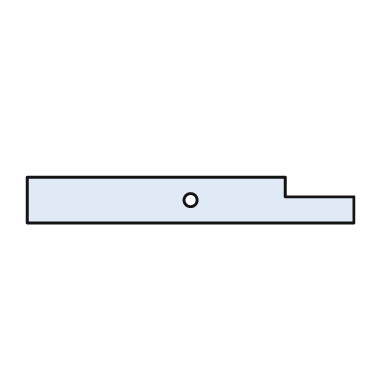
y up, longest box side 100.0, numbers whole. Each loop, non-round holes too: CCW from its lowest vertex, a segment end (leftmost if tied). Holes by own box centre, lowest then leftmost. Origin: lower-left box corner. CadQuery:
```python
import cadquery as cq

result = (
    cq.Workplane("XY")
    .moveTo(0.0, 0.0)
    .lineTo(100.0, 0.0)
    .lineTo(100.0, 8.0)
    .lineTo(79.0, 8.0)
    .lineTo(79.0, 14.0)
    .lineTo(0.0, 14.0)
    .close()
    .moveTo(50.0, 7.0)
    .circle(2.0)
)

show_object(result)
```